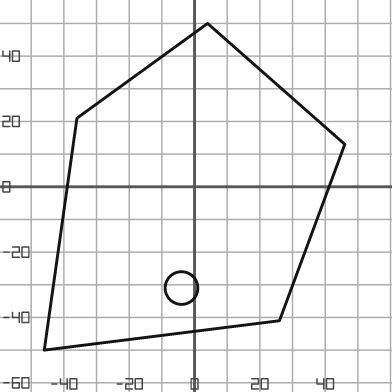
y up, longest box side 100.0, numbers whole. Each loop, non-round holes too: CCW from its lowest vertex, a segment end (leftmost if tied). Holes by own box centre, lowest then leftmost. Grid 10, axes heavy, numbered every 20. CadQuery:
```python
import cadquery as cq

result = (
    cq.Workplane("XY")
    .moveTo(-46.0, -50.0)
    .lineTo(26.0, -41.0)
    .lineTo(46.0, 13.0)
    .lineTo(4.0, 50.0)
    .lineTo(-36.0, 21.0)
    .close()
    .moveTo(-4.0, -31.0)
    .circle(5.0)
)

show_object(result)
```